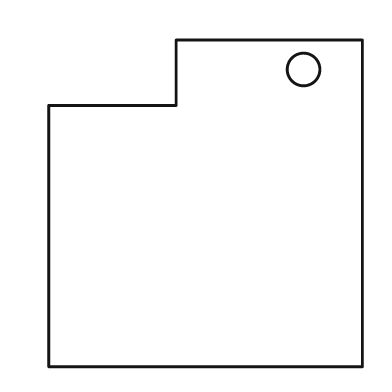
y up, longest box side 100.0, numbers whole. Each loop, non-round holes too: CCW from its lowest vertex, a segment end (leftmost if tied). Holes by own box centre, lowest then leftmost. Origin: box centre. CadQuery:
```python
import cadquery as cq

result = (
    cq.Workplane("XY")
    .moveTo(-48.0, -50.0)
    .lineTo(48.0, -50.0)
    .lineTo(48.0, 50.0)
    .lineTo(-9.0, 50.0)
    .lineTo(-9.0, 30.0)
    .lineTo(-48.0, 30.0)
    .close()
    .moveTo(30.0, 41.0)
    .circle(5.0)
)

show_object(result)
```